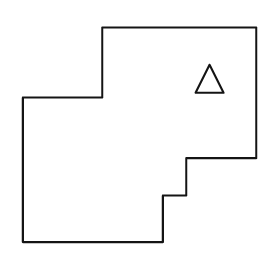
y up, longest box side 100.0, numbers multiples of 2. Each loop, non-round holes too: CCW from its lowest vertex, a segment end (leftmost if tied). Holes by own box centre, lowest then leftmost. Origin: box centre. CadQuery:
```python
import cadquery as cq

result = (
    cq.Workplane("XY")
    .moveTo(-50.0, -46.0)
    .lineTo(10.0, -46.0)
    .lineTo(10.0, -26.0)
    .lineTo(20.0, -26.0)
    .lineTo(20.0, -10.0)
    .lineTo(50.0, -10.0)
    .lineTo(50.0, 46.0)
    .lineTo(-16.0, 46.0)
    .lineTo(-16.0, 16.0)
    .lineTo(-50.0, 16.0)
    .close()
    .moveTo(24.0, 18.0)
    .lineTo(36.0, 18.0)
    .lineTo(30.0, 30.0)
    .close()
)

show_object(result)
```